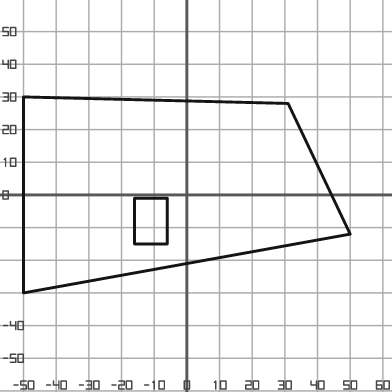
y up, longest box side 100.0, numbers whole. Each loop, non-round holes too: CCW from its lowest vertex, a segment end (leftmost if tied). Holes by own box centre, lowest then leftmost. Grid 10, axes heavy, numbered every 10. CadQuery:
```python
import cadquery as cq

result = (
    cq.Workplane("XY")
    .moveTo(-50.0, -30.0)
    .lineTo(50.0, -12.0)
    .lineTo(31.0, 28.0)
    .lineTo(-50.0, 30.0)
    .close()
    .moveTo(-16.0, -15.0)
    .lineTo(-6.0, -15.0)
    .lineTo(-6.0, -1.0)
    .lineTo(-16.0, -1.0)
    .close()
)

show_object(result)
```